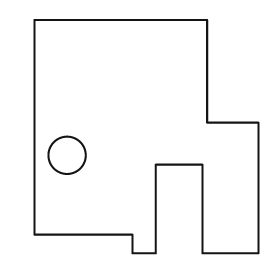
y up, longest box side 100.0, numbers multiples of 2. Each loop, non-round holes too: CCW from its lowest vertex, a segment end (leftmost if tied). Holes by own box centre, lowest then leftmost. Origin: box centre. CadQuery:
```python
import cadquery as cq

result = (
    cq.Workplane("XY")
    .moveTo(-6.0, -50.0)
    .lineTo(4.0, -50.0)
    .lineTo(4.0, -12.0)
    .lineTo(24.0, -12.0)
    .lineTo(24.0, -50.0)
    .lineTo(48.0, -50.0)
    .lineTo(48.0, 6.0)
    .lineTo(26.0, 6.0)
    .lineTo(26.0, 50.0)
    .lineTo(-48.0, 50.0)
    .lineTo(-48.0, -42.0)
    .lineTo(-6.0, -42.0)
    .close()
    .moveTo(-34.0, -8.0)
    .circle(8.0)
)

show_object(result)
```